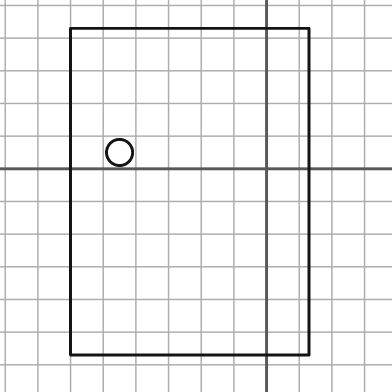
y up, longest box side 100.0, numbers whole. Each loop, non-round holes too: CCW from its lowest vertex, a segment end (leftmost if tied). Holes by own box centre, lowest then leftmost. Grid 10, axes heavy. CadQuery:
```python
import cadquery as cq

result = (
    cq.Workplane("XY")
    .moveTo(-60.0, -57.0)
    .lineTo(13.0, -57.0)
    .lineTo(13.0, 43.0)
    .lineTo(-60.0, 43.0)
    .close()
    .moveTo(-45.0, 5.0)
    .circle(4.0)
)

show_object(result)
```